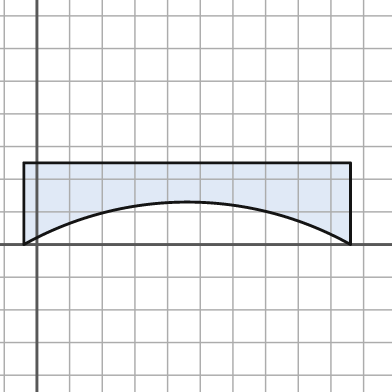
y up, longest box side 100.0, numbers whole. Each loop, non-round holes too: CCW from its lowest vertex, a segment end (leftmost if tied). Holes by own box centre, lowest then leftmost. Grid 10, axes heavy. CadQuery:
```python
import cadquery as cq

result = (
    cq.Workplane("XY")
    .moveTo(-4.0, 0.0)
    .threePointArc((46.0, 13.0), (96.0, 0.0))
    .lineTo(96.0, 25.0)
    .lineTo(-4.0, 25.0)
    .close()
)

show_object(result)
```